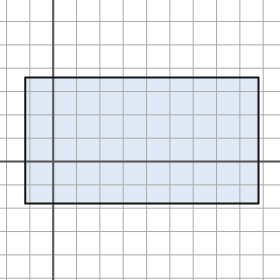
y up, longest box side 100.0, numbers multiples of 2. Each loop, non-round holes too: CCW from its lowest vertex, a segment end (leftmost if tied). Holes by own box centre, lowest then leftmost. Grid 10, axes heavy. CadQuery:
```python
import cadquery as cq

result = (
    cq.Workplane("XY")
    .moveTo(-12.0, -18.0)
    .lineTo(88.0, -18.0)
    .lineTo(88.0, 36.0)
    .lineTo(-12.0, 36.0)
    .close()
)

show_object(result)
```